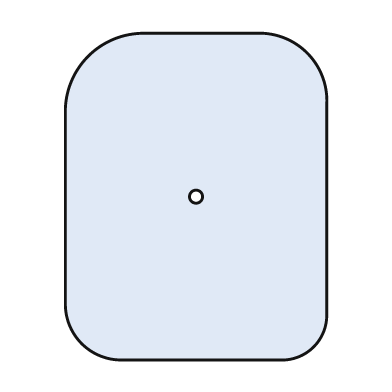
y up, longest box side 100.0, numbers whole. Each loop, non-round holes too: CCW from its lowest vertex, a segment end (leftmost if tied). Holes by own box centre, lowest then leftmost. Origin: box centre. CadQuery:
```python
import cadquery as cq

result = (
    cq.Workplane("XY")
    .moveTo(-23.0, -50.0)
    .lineTo(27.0, -50.0)
    .threePointArc((36.0, -46.0), (40.0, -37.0))
    .lineTo(40.0, 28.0)
    .threePointArc((34.0, 44.0), (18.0, 50.0))
    .lineTo(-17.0, 50.0)
    .threePointArc((-33.0, 43.0), (-40.0, 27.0))
    .lineTo(-40.0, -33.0)
    .threePointArc((-35.0, -45.0), (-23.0, -50.0))
    .close()
    .moveTo(0.0, 0.0)
    .circle(2.0)
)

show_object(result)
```